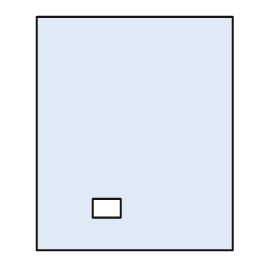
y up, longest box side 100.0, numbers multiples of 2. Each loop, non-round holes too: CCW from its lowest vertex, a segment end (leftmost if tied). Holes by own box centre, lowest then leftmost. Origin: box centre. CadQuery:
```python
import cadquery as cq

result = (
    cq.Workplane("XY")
    .moveTo(-42.0, -50.0)
    .lineTo(42.0, -50.0)
    .lineTo(42.0, 50.0)
    .lineTo(-42.0, 50.0)
    .close()
    .moveTo(-18.0, -36.0)
    .lineTo(-6.0, -36.0)
    .lineTo(-6.0, -28.0)
    .lineTo(-18.0, -28.0)
    .close()
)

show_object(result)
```